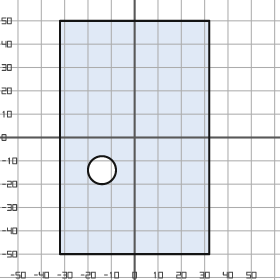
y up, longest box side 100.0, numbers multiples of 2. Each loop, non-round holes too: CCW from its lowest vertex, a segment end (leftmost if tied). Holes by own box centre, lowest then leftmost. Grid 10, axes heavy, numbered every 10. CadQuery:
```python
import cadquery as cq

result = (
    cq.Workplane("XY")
    .moveTo(-32.0, -50.0)
    .lineTo(32.0, -50.0)
    .lineTo(32.0, 50.0)
    .lineTo(-32.0, 50.0)
    .close()
    .moveTo(-14.0, -14.0)
    .circle(6.0)
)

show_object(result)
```